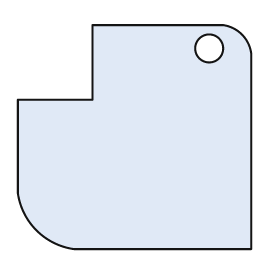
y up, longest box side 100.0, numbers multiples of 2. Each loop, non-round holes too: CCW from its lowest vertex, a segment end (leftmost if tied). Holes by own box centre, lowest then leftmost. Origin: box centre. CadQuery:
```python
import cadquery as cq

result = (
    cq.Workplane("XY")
    .moveTo(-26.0, -48.0)
    .lineTo(50.0, -48.0)
    .lineTo(50.0, 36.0)
    .threePointArc((46.0, 44.0), (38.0, 48.0))
    .lineTo(-18.0, 48.0)
    .lineTo(-18.0, 16.0)
    .lineTo(-50.0, 16.0)
    .lineTo(-50.0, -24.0)
    .threePointArc((-42.0, -40.0), (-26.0, -48.0))
    .close()
    .moveTo(32.0, 38.0)
    .circle(6.0)
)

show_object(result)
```